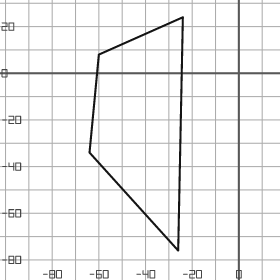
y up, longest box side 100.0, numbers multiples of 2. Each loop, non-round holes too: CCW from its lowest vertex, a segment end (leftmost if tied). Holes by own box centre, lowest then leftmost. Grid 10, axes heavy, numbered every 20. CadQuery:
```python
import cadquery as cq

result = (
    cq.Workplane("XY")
    .moveTo(-26.0, -76.0)
    .lineTo(-24.0, 24.0)
    .lineTo(-60.0, 8.0)
    .lineTo(-64.0, -34.0)
    .close()
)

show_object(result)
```